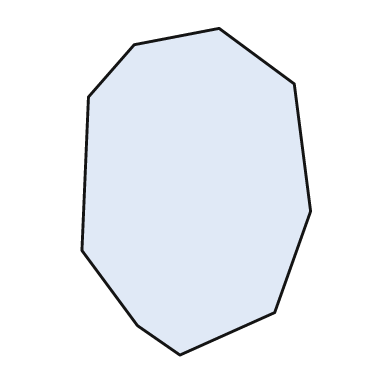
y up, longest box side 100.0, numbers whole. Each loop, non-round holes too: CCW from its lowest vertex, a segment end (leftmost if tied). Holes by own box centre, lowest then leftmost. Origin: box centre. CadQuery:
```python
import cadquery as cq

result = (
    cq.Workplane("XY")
    .moveTo(-5.0, -50.0)
    .lineTo(24.0, -37.0)
    .lineTo(35.0, -6.0)
    .lineTo(30.0, 33.0)
    .lineTo(7.0, 50.0)
    .lineTo(-19.0, 45.0)
    .lineTo(-33.0, 29.0)
    .lineTo(-35.0, -18.0)
    .lineTo(-18.0, -41.0)
    .close()
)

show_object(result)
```